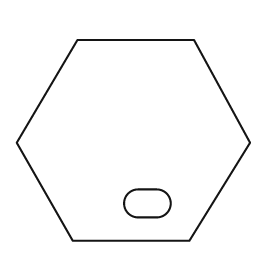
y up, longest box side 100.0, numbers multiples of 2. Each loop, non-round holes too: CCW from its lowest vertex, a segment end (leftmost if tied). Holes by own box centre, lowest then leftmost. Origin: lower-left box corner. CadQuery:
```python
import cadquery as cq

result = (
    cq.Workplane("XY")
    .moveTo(24.0, 0.0)
    .lineTo(74.0, 0.0)
    .lineTo(100.0, 42.0)
    .lineTo(76.0, 86.0)
    .lineTo(26.0, 86.0)
    .lineTo(0.0, 42.0)
    .close()
    .moveTo(52.0, 10.0)
    .lineTo(60.0, 10.0)
    .threePointArc((66.0, 16.0), (60.0, 22.0))
    .lineTo(52.0, 22.0)
    .threePointArc((46.0, 16.0), (52.0, 10.0))
    .close()
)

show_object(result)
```